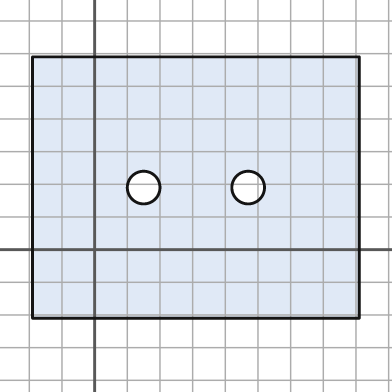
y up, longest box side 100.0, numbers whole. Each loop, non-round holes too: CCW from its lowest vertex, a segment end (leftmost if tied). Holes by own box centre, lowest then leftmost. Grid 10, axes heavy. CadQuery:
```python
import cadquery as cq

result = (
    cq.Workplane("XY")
    .moveTo(-19.0, -21.0)
    .lineTo(81.0, -21.0)
    .lineTo(81.0, 59.0)
    .lineTo(-19.0, 59.0)
    .close()
    .moveTo(15.0, 19.0)
    .circle(5.0)
    .moveTo(47.0, 19.0)
    .circle(5.0)
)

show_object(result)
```